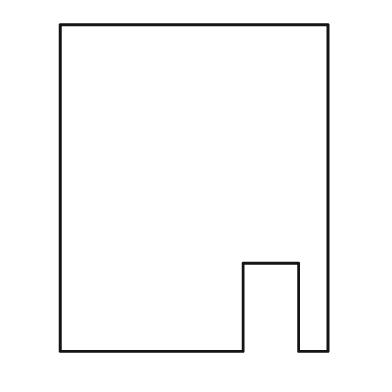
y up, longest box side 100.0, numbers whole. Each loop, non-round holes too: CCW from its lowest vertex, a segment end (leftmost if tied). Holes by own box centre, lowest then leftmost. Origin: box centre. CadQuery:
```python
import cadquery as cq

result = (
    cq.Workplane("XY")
    .moveTo(-41.0, -50.0)
    .lineTo(15.0, -50.0)
    .lineTo(15.0, -23.0)
    .lineTo(32.0, -23.0)
    .lineTo(32.0, -50.0)
    .lineTo(41.0, -50.0)
    .lineTo(41.0, 50.0)
    .lineTo(-41.0, 50.0)
    .close()
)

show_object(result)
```